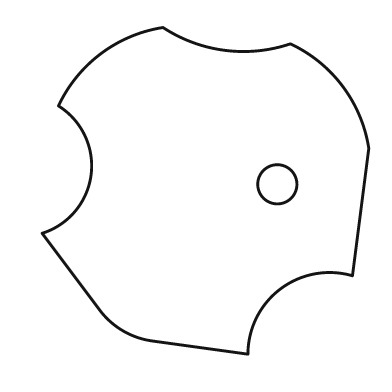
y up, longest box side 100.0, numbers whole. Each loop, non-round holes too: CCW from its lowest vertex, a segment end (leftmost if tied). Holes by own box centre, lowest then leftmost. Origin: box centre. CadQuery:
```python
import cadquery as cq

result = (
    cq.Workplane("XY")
    .moveTo(13.0, -50.0)
    .threePointArc((23.0, -30.0), (45.0, -26.0))
    .lineTo(50.0, 13.0)
    .threePointArc((42.0, 32.0), (26.0, 45.0))
    .threePointArc((6.0, 43.0), (-13.0, 50.0))
    .threePointArc((-32.0, 42.0), (-45.0, 26.0))
    .threePointArc((-35.0, 5.0), (-50.0, -13.0))
    .lineTo(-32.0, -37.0)
    .threePointArc((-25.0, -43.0), (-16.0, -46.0))
    .close()
    .moveTo(22.0, 2.0)
    .circle(6.0)
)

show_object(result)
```